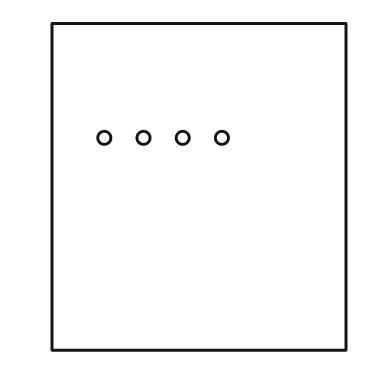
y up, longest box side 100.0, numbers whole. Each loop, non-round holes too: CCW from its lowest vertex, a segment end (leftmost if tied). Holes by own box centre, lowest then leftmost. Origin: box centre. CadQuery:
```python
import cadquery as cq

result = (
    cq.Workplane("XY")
    .moveTo(-45.0, -50.0)
    .lineTo(45.0, -50.0)
    .lineTo(45.0, 50.0)
    .lineTo(-45.0, 50.0)
    .close()
    .moveTo(-29.0, 15.0)
    .circle(2.0)
    .moveTo(-17.0, 15.0)
    .circle(2.0)
    .moveTo(-5.0, 15.0)
    .circle(2.0)
    .moveTo(7.0, 15.0)
    .circle(2.0)
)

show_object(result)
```